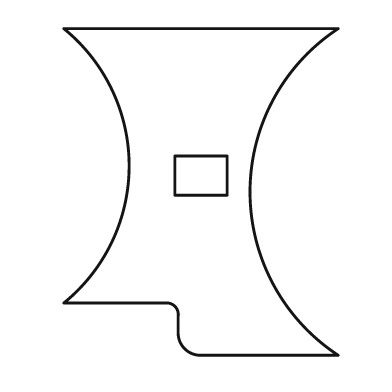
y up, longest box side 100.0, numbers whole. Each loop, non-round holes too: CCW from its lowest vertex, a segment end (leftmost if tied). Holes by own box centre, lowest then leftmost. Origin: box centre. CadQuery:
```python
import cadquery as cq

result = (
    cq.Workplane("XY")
    .moveTo(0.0, -50.0)
    .lineTo(42.0, -50.0)
    .threePointArc((15.0, 0.0), (42.0, 50.0))
    .lineTo(-42.0, 50.0)
    .threePointArc((-22.0, 8.0), (-42.0, -34.0))
    .lineTo(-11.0, -34.0)
    .threePointArc((-8.0, -35.0), (-7.0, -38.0))
    .lineTo(-7.0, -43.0)
    .threePointArc((-5.0, -48.0), (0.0, -50.0))
    .close()
    .moveTo(-8.0, -1.0)
    .lineTo(8.0, -1.0)
    .lineTo(8.0, 11.0)
    .lineTo(-8.0, 11.0)
    .close()
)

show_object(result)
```